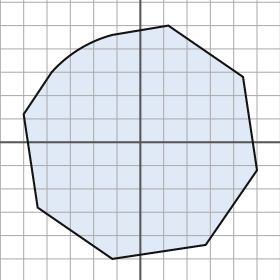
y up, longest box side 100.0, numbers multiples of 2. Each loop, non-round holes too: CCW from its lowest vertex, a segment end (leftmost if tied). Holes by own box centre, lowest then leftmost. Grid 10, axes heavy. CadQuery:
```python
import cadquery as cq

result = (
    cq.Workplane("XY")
    .moveTo(-12.0, -50.0)
    .lineTo(28.0, -44.0)
    .lineTo(50.0, -12.0)
    .lineTo(44.0, 28.0)
    .lineTo(12.0, 50.0)
    .lineTo(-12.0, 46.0)
    .threePointArc((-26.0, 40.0), (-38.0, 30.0))
    .lineTo(-50.0, 12.0)
    .lineTo(-44.0, -28.0)
    .close()
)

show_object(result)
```